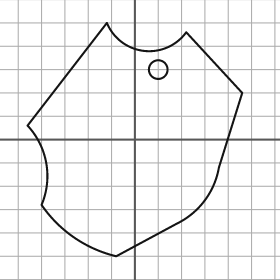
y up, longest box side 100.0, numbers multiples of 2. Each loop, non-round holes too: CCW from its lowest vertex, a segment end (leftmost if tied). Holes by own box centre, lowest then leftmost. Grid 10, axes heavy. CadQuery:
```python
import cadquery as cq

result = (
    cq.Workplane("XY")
    .moveTo(-8.0, -50.0)
    .lineTo(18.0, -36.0)
    .threePointArc((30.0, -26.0), (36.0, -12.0))
    .lineTo(46.0, 20.0)
    .lineTo(22.0, 46.0)
    .threePointArc((4.0, 38.0), (-12.0, 50.0))
    .lineTo(-46.0, 6.0)
    .threePointArc((-38.0, -10.0), (-40.0, -28.0))
    .threePointArc((-26.0, -42.0), (-8.0, -50.0))
    .close()
    .moveTo(10.0, 30.0)
    .circle(4.0)
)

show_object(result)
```